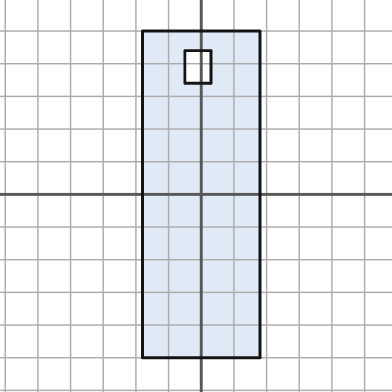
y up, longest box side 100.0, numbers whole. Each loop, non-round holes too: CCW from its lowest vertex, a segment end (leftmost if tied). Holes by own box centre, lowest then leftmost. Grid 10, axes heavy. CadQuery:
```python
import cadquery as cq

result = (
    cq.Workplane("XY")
    .moveTo(-18.0, -50.0)
    .lineTo(18.0, -50.0)
    .lineTo(18.0, 50.0)
    .lineTo(-18.0, 50.0)
    .close()
    .moveTo(-5.0, 34.0)
    .lineTo(3.0, 34.0)
    .lineTo(3.0, 44.0)
    .lineTo(-5.0, 44.0)
    .close()
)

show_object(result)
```